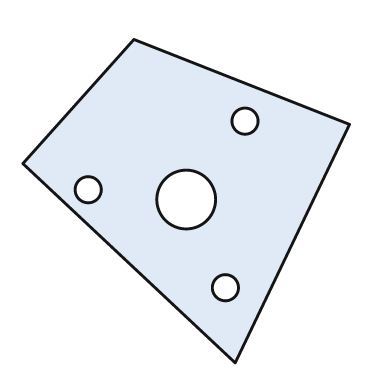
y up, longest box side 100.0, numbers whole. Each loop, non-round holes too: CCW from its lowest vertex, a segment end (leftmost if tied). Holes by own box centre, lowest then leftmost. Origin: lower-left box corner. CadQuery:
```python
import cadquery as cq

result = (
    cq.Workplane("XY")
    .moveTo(65.0, 0.0)
    .lineTo(100.0, 73.0)
    .lineTo(34.0, 99.0)
    .lineTo(0.0, 61.0)
    .close()
    .moveTo(62.0, 23.0)
    .circle(4.0)
    .moveTo(50.0, 50.0)
    .circle(9.0)
    .moveTo(20.0, 53.0)
    .circle(4.0)
    .moveTo(68.0, 74.0)
    .circle(4.0)
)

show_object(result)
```